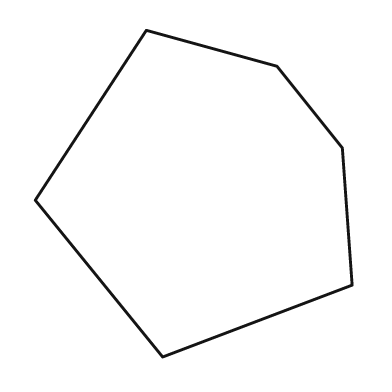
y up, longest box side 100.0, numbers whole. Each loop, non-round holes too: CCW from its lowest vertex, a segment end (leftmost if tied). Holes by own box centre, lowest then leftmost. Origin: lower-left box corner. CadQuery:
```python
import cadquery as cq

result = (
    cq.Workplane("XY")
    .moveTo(39.0, 0.0)
    .lineTo(97.0, 22.0)
    .lineTo(94.0, 64.0)
    .lineTo(74.0, 89.0)
    .lineTo(34.0, 100.0)
    .lineTo(0.0, 48.0)
    .close()
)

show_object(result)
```